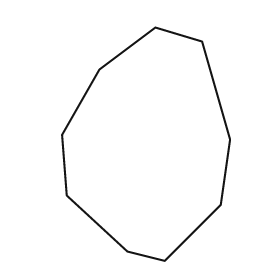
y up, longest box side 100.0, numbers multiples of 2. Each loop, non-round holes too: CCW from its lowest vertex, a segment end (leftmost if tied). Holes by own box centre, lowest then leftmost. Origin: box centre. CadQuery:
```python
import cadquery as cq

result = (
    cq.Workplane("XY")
    .moveTo(8.0, -50.0)
    .lineTo(32.0, -26.0)
    .lineTo(36.0, 2.0)
    .lineTo(24.0, 44.0)
    .lineTo(4.0, 50.0)
    .lineTo(-20.0, 32.0)
    .lineTo(-36.0, 4.0)
    .lineTo(-34.0, -22.0)
    .lineTo(-8.0, -46.0)
    .close()
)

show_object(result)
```